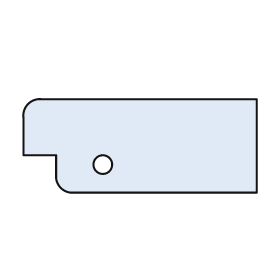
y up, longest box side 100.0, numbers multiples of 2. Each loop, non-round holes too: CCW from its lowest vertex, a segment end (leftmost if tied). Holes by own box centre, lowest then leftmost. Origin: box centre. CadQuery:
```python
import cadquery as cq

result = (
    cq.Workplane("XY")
    .moveTo(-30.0, -20.0)
    .lineTo(50.0, -20.0)
    .lineTo(50.0, 20.0)
    .lineTo(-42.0, 20.0)
    .threePointArc((-48.0, 18.0), (-50.0, 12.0))
    .lineTo(-50.0, -4.0)
    .lineTo(-36.0, -4.0)
    .lineTo(-36.0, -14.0)
    .threePointArc((-34.0, -18.0), (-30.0, -20.0))
    .close()
    .moveTo(-16.0, -8.0)
    .circle(4.0)
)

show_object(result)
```